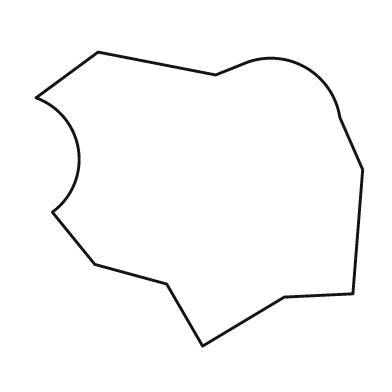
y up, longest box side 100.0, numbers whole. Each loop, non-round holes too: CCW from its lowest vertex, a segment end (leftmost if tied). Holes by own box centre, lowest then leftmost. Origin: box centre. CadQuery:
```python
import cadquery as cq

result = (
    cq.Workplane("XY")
    .moveTo(1.0, -45.0)
    .lineTo(26.0, -30.0)
    .lineTo(47.0, -29.0)
    .lineTo(50.0, 9.0)
    .lineTo(43.0, 25.0)
    .threePointArc((33.0, 40.0), (15.0, 42.0))
    .lineTo(5.0, 38.0)
    .lineTo(-31.0, 45.0)
    .lineTo(-50.0, 31.0)
    .threePointArc((-37.0, 15.0), (-45.0, -4.0))
    .lineTo(-32.0, -20.0)
    .lineTo(-10.0, -26.0)
    .close()
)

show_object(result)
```